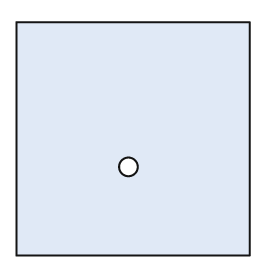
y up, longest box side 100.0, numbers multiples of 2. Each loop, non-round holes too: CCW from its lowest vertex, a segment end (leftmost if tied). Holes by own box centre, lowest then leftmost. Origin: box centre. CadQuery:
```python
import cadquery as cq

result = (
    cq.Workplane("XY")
    .moveTo(-50.0, -50.0)
    .lineTo(50.0, -50.0)
    .lineTo(50.0, 50.0)
    .lineTo(-50.0, 50.0)
    .close()
    .moveTo(-2.0, -12.0)
    .circle(4.0)
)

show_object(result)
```